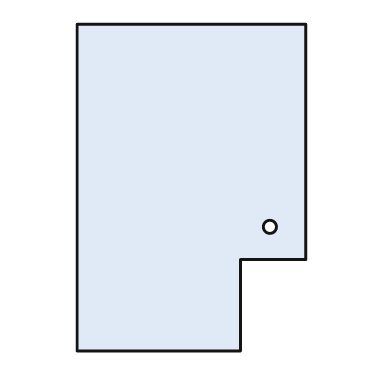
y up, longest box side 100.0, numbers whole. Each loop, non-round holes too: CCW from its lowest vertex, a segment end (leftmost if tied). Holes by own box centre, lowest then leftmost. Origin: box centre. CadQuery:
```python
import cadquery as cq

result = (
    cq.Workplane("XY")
    .moveTo(-35.0, -50.0)
    .lineTo(15.0, -50.0)
    .lineTo(15.0, -22.0)
    .lineTo(35.0, -22.0)
    .lineTo(35.0, 50.0)
    .lineTo(-35.0, 50.0)
    .close()
    .moveTo(24.0, -12.0)
    .circle(2.0)
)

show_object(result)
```